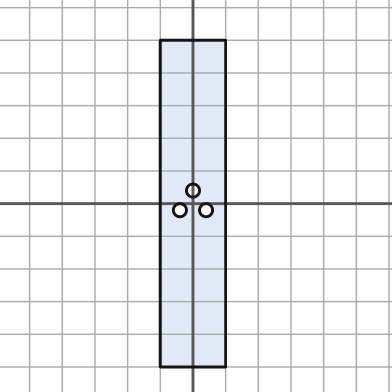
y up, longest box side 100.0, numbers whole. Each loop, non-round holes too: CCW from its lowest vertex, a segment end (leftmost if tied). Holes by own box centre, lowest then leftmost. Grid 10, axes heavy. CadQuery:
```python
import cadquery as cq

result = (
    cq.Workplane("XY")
    .moveTo(-10.0, -50.0)
    .lineTo(10.0, -50.0)
    .lineTo(10.0, 50.0)
    .lineTo(-10.0, 50.0)
    .close()
    .moveTo(-4.0, -2.0)
    .circle(2.0)
    .moveTo(4.0, -2.0)
    .circle(2.0)
    .moveTo(0.0, 4.0)
    .circle(2.0)
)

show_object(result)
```